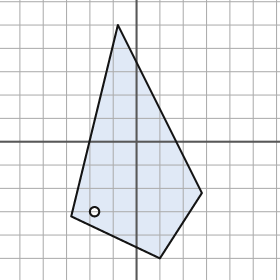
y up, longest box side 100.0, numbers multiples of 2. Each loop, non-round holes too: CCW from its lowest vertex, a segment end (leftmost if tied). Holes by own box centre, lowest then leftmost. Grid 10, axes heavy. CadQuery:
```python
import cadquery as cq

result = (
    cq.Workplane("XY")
    .moveTo(10.0, -50.0)
    .lineTo(28.0, -22.0)
    .lineTo(-8.0, 50.0)
    .lineTo(-28.0, -32.0)
    .close()
    .moveTo(-18.0, -30.0)
    .circle(2.0)
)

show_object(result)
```